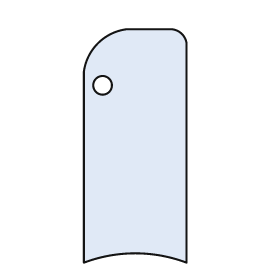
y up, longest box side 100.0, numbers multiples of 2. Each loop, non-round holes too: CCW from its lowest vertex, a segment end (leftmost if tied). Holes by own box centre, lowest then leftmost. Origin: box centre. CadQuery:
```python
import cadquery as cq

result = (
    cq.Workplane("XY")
    .moveTo(-22.0, -50.0)
    .threePointArc((0.0, -46.0), (22.0, -50.0))
    .lineTo(22.0, 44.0)
    .threePointArc((20.0, 48.0), (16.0, 50.0))
    .lineTo(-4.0, 50.0)
    .threePointArc((-16.0, 44.0), (-22.0, 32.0))
    .close()
    .moveTo(-14.0, 26.0)
    .circle(4.0)
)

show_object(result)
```